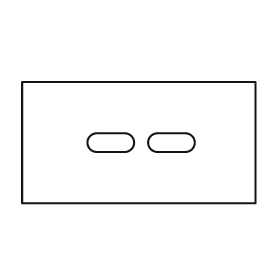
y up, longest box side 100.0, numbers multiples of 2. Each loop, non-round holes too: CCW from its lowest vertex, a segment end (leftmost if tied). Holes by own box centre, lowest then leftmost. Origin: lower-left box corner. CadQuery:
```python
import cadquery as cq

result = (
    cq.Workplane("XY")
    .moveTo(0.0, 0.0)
    .lineTo(100.0, 0.0)
    .lineTo(100.0, 52.0)
    .lineTo(0.0, 52.0)
    .close()
    .moveTo(32.0, 22.0)
    .lineTo(44.0, 22.0)
    .threePointArc((48.0, 26.0), (44.0, 30.0))
    .lineTo(32.0, 30.0)
    .threePointArc((28.0, 26.0), (32.0, 22.0))
    .close()
    .moveTo(58.0, 22.0)
    .lineTo(70.0, 22.0)
    .threePointArc((74.0, 26.0), (70.0, 30.0))
    .lineTo(58.0, 30.0)
    .threePointArc((54.0, 26.0), (58.0, 22.0))
    .close()
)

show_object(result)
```